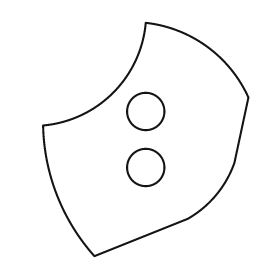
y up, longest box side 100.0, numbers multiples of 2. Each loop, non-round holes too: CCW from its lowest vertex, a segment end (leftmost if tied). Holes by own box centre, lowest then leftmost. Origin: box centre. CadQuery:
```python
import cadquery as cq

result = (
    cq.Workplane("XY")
    .moveTo(-22.0, -50.0)
    .lineTo(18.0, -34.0)
    .threePointArc((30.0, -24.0), (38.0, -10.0))
    .lineTo(44.0, 18.0)
    .threePointArc((26.0, 40.0), (0.0, 50.0))
    .threePointArc((-14.0, 20.0), (-44.0, 6.0))
    .threePointArc((-38.0, -24.0), (-22.0, -50.0))
    .close()
    .moveTo(0.0, -12.0)
    .circle(8.0)
    .moveTo(0.0, 12.0)
    .circle(8.0)
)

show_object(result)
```